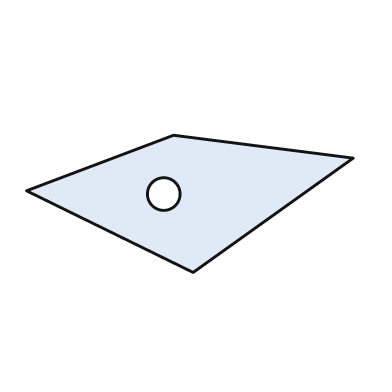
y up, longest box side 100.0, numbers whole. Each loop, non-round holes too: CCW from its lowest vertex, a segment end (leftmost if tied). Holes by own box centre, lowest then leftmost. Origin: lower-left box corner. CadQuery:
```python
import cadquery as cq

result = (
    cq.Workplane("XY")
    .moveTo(51.0, 0.0)
    .lineTo(100.0, 35.0)
    .lineTo(45.0, 42.0)
    .lineTo(0.0, 25.0)
    .close()
    .moveTo(42.0, 24.0)
    .circle(5.0)
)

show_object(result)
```